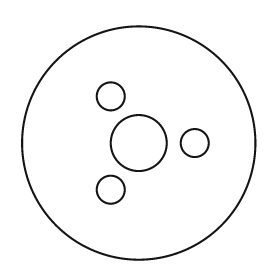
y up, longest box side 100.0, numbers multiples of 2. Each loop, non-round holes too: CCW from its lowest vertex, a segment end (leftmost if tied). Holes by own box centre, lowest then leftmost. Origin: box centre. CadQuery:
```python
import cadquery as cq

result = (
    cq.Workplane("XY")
    .moveTo(0.0, 0.0)
    .circle(50.0)
    .moveTo(-12.0, -20.0)
    .circle(6.0)
    .moveTo(0.0, 0.0)
    .circle(12.0)
    .moveTo(24.0, 0.0)
    .circle(6.0)
    .moveTo(-12.0, 20.0)
    .circle(6.0)
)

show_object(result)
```